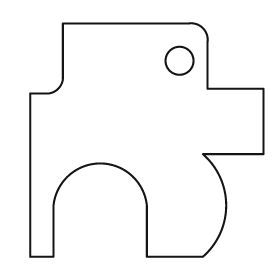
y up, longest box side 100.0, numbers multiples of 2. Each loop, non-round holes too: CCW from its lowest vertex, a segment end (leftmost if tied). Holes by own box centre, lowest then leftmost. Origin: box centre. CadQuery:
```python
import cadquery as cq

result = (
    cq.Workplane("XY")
    .moveTo(-50.0, -50.0)
    .lineTo(-40.0, -50.0)
    .lineTo(-40.0, -28.0)
    .threePointArc((-20.0, -10.0), (0.0, -28.0))
    .lineTo(0.0, -50.0)
    .lineTo(24.0, -50.0)
    .threePointArc((34.0, -28.0), (24.0, -6.0))
    .lineTo(50.0, -6.0)
    .lineTo(50.0, 22.0)
    .lineTo(26.0, 22.0)
    .lineTo(26.0, 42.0)
    .threePointArc((24.0, 48.0), (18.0, 50.0))
    .lineTo(-36.0, 50.0)
    .lineTo(-36.0, 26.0)
    .threePointArc((-38.0, 22.0), (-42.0, 20.0))
    .lineTo(-50.0, 20.0)
    .close()
    .moveTo(14.0, 34.0)
    .circle(6.0)
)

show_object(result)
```